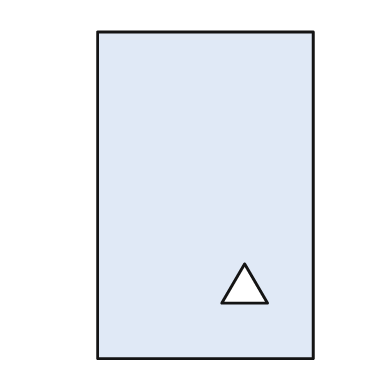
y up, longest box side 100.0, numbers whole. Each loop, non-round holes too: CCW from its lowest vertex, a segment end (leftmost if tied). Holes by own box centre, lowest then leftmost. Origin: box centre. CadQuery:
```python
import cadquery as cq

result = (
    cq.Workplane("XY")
    .moveTo(-33.0, -50.0)
    .lineTo(33.0, -50.0)
    .lineTo(33.0, 50.0)
    .lineTo(-33.0, 50.0)
    .close()
    .moveTo(5.0, -33.0)
    .lineTo(19.0, -33.0)
    .lineTo(12.0, -21.0)
    .close()
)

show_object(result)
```